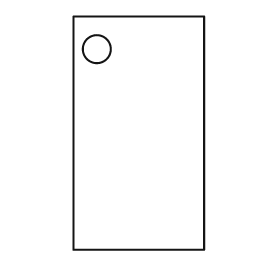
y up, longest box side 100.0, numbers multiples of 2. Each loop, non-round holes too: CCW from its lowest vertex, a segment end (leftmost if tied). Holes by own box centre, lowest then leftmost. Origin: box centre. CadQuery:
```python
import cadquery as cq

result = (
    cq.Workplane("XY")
    .moveTo(-28.0, -50.0)
    .lineTo(28.0, -50.0)
    .lineTo(28.0, 50.0)
    .lineTo(-28.0, 50.0)
    .close()
    .moveTo(-18.0, 36.0)
    .circle(6.0)
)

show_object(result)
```